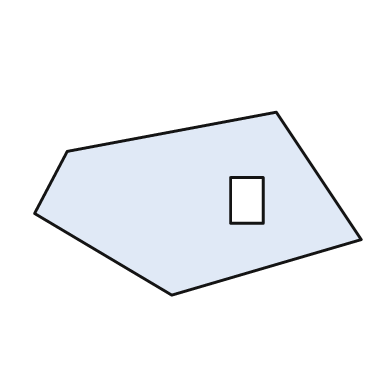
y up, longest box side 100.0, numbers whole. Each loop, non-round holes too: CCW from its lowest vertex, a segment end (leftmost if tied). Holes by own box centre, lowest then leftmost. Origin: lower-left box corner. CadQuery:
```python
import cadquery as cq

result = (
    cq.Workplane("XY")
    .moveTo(42.0, 0.0)
    .lineTo(100.0, 17.0)
    .lineTo(74.0, 56.0)
    .lineTo(10.0, 44.0)
    .lineTo(0.0, 25.0)
    .close()
    .moveTo(60.0, 22.0)
    .lineTo(70.0, 22.0)
    .lineTo(70.0, 36.0)
    .lineTo(60.0, 36.0)
    .close()
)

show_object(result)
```